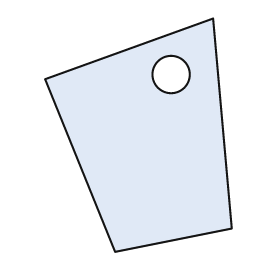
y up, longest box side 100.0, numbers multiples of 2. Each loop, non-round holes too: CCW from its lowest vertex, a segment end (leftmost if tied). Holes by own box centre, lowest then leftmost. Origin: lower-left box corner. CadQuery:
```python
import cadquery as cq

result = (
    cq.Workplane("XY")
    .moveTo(30.0, 0.0)
    .lineTo(80.0, 10.0)
    .lineTo(72.0, 100.0)
    .lineTo(0.0, 74.0)
    .close()
    .moveTo(54.0, 76.0)
    .circle(8.0)
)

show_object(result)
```